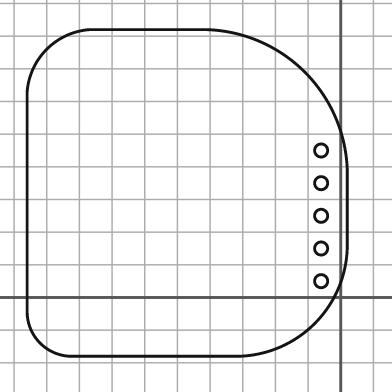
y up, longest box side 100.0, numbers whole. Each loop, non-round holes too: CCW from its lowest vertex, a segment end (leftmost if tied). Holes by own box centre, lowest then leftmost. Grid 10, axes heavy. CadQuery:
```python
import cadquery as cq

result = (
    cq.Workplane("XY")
    .moveTo(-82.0, -18.0)
    .lineTo(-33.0, -18.0)
    .threePointArc((-8.0, -8.0), (2.0, 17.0))
    .lineTo(2.0, 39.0)
    .threePointArc((-11.0, 69.0), (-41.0, 82.0))
    .lineTo(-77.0, 82.0)
    .threePointArc((-90.0, 76.0), (-96.0, 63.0))
    .lineTo(-96.0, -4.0)
    .threePointArc((-92.0, -14.0), (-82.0, -18.0))
    .close()
    .moveTo(-6.0, 5.0)
    .circle(2.0)
    .moveTo(-6.0, 15.0)
    .circle(2.0)
    .moveTo(-6.0, 25.0)
    .circle(2.0)
    .moveTo(-6.0, 35.0)
    .circle(2.0)
    .moveTo(-6.0, 45.0)
    .circle(2.0)
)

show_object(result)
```